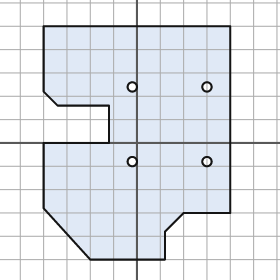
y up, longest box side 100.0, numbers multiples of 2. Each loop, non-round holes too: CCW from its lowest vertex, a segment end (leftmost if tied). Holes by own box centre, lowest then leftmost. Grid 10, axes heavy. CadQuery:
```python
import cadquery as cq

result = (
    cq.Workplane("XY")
    .moveTo(-20.0, -50.0)
    .lineTo(12.0, -50.0)
    .lineTo(12.0, -38.0)
    .lineTo(20.0, -30.0)
    .lineTo(40.0, -30.0)
    .lineTo(40.0, 50.0)
    .lineTo(-40.0, 50.0)
    .lineTo(-40.0, 22.0)
    .lineTo(-34.0, 16.0)
    .lineTo(-12.0, 16.0)
    .lineTo(-12.0, 0.0)
    .lineTo(-40.0, 0.0)
    .lineTo(-40.0, -28.0)
    .close()
    .moveTo(-2.0, -8.0)
    .circle(2.0)
    .moveTo(30.0, -8.0)
    .circle(2.0)
    .moveTo(-2.0, 24.0)
    .circle(2.0)
    .moveTo(30.0, 24.0)
    .circle(2.0)
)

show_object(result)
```